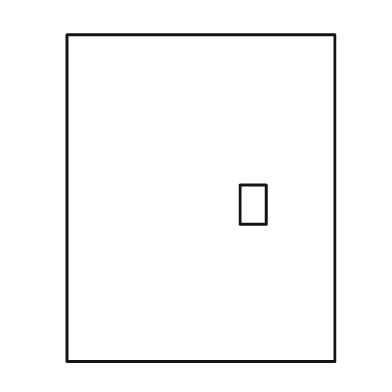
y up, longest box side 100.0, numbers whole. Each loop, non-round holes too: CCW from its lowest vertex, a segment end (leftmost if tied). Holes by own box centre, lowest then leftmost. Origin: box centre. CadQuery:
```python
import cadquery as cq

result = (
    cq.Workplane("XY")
    .moveTo(-41.0, -50.0)
    .lineTo(41.0, -50.0)
    .lineTo(41.0, 50.0)
    .lineTo(-41.0, 50.0)
    .close()
    .moveTo(12.0, -8.0)
    .lineTo(20.0, -8.0)
    .lineTo(20.0, 4.0)
    .lineTo(12.0, 4.0)
    .close()
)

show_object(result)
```